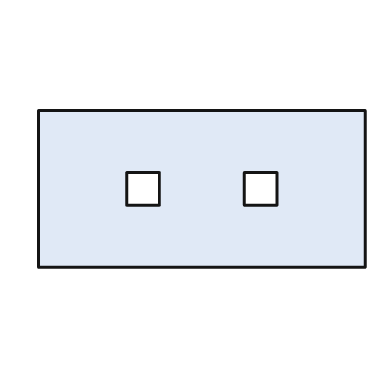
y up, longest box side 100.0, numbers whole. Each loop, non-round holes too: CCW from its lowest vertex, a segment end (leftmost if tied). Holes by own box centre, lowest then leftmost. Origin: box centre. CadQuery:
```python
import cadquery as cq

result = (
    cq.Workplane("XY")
    .moveTo(-50.0, -24.0)
    .lineTo(50.0, -24.0)
    .lineTo(50.0, 24.0)
    .lineTo(-50.0, 24.0)
    .close()
    .moveTo(-23.0, -5.0)
    .lineTo(-13.0, -5.0)
    .lineTo(-13.0, 5.0)
    .lineTo(-23.0, 5.0)
    .close()
    .moveTo(13.0, -5.0)
    .lineTo(23.0, -5.0)
    .lineTo(23.0, 5.0)
    .lineTo(13.0, 5.0)
    .close()
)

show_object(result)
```